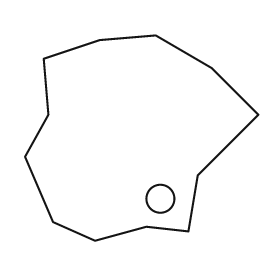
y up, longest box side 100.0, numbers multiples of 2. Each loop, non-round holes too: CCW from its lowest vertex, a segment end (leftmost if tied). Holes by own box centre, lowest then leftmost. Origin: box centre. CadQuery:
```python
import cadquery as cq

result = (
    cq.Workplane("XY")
    .moveTo(-20.0, -44.0)
    .lineTo(2.0, -38.0)
    .lineTo(20.0, -40.0)
    .lineTo(24.0, -16.0)
    .lineTo(50.0, 10.0)
    .lineTo(30.0, 30.0)
    .lineTo(6.0, 44.0)
    .lineTo(-18.0, 42.0)
    .lineTo(-42.0, 34.0)
    .lineTo(-40.0, 10.0)
    .lineTo(-50.0, -8.0)
    .lineTo(-38.0, -36.0)
    .close()
    .moveTo(8.0, -26.0)
    .circle(6.0)
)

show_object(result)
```